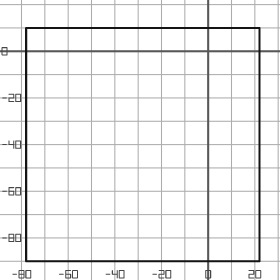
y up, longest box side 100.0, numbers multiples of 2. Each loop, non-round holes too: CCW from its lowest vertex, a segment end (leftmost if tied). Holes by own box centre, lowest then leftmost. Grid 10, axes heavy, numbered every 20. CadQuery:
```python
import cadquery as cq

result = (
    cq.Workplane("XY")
    .moveTo(-78.0, -90.0)
    .lineTo(22.0, -90.0)
    .lineTo(22.0, 10.0)
    .lineTo(-78.0, 10.0)
    .close()
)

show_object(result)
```